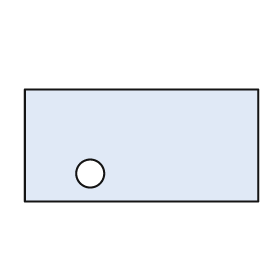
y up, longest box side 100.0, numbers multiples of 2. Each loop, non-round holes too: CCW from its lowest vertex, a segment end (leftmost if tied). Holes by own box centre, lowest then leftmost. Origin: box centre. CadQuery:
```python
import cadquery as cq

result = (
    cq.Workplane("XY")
    .moveTo(-50.0, -24.0)
    .lineTo(50.0, -24.0)
    .lineTo(50.0, 24.0)
    .lineTo(-50.0, 24.0)
    .close()
    .moveTo(-22.0, -12.0)
    .circle(6.0)
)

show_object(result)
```